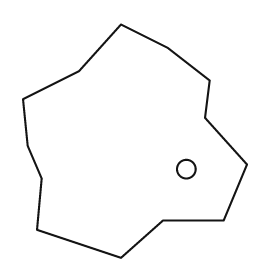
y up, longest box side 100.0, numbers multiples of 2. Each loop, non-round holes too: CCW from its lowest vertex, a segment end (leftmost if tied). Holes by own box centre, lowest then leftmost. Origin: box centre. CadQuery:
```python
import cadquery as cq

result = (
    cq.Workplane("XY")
    .moveTo(-6.0, -50.0)
    .lineTo(12.0, -34.0)
    .lineTo(38.0, -34.0)
    .lineTo(48.0, -10.0)
    .lineTo(30.0, 10.0)
    .lineTo(32.0, 26.0)
    .lineTo(14.0, 40.0)
    .lineTo(-6.0, 50.0)
    .lineTo(-24.0, 30.0)
    .lineTo(-48.0, 18.0)
    .lineTo(-46.0, -2.0)
    .lineTo(-40.0, -16.0)
    .lineTo(-42.0, -38.0)
    .close()
    .moveTo(22.0, -12.0)
    .circle(4.0)
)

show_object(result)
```